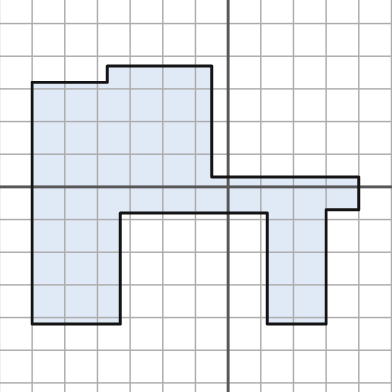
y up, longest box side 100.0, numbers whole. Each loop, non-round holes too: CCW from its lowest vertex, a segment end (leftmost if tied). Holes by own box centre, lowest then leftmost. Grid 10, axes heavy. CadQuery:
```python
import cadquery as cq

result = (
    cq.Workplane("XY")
    .moveTo(-60.0, -42.0)
    .lineTo(-33.0, -42.0)
    .lineTo(-33.0, -8.0)
    .lineTo(12.0, -8.0)
    .lineTo(12.0, -42.0)
    .lineTo(30.0, -42.0)
    .lineTo(30.0, -7.0)
    .lineTo(40.0, -7.0)
    .lineTo(40.0, 3.0)
    .lineTo(-5.0, 3.0)
    .lineTo(-5.0, 37.0)
    .lineTo(-37.0, 37.0)
    .lineTo(-37.0, 32.0)
    .lineTo(-60.0, 32.0)
    .close()
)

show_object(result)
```